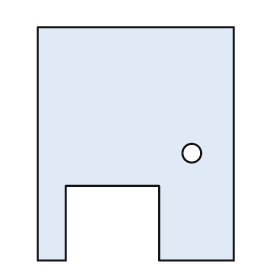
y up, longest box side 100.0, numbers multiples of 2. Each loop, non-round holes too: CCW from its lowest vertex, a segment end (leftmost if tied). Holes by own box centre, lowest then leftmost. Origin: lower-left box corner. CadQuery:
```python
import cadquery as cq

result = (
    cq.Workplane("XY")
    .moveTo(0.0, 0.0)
    .lineTo(12.0, 0.0)
    .lineTo(12.0, 32.0)
    .lineTo(52.0, 32.0)
    .lineTo(52.0, 0.0)
    .lineTo(84.0, 0.0)
    .lineTo(84.0, 100.0)
    .lineTo(0.0, 100.0)
    .close()
    .moveTo(66.0, 46.0)
    .circle(4.0)
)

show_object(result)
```